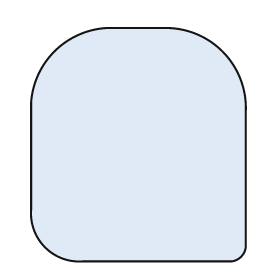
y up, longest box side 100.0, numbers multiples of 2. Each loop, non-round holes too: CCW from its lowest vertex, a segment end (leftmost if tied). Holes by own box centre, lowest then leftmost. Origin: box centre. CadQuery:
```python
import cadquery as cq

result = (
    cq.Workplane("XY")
    .moveTo(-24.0, -50.0)
    .lineTo(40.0, -50.0)
    .threePointArc((44.0, -48.0), (46.0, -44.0))
    .lineTo(46.0, 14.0)
    .threePointArc((36.0, 40.0), (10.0, 50.0))
    .lineTo(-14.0, 50.0)
    .threePointArc((-36.0, 40.0), (-46.0, 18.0))
    .lineTo(-46.0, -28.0)
    .threePointArc((-40.0, -44.0), (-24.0, -50.0))
    .close()
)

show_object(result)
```